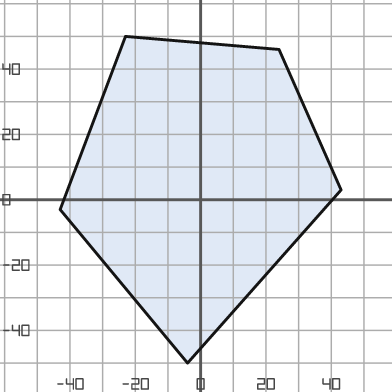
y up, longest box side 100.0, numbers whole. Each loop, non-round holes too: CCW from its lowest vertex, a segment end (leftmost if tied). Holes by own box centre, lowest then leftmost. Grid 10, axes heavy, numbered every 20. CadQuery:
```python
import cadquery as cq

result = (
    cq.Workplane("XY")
    .moveTo(-4.0, -50.0)
    .lineTo(43.0, 3.0)
    .lineTo(24.0, 46.0)
    .lineTo(-23.0, 50.0)
    .lineTo(-43.0, -3.0)
    .close()
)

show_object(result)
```